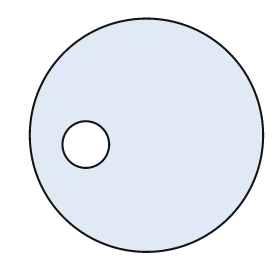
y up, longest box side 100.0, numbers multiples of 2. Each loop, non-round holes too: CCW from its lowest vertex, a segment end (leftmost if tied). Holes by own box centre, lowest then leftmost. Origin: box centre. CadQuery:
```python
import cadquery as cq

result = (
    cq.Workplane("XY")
    .moveTo(0.0, 0.0)
    .circle(50.0)
    .moveTo(-26.0, -4.0)
    .circle(10.0)
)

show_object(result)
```